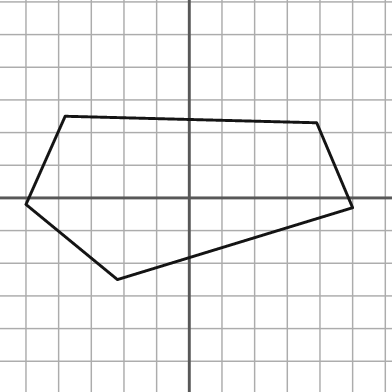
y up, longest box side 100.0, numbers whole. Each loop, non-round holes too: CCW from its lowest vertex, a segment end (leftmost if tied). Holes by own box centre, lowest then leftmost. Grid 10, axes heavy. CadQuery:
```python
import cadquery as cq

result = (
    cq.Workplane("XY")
    .moveTo(-22.0, -25.0)
    .lineTo(50.0, -3.0)
    .lineTo(39.0, 23.0)
    .lineTo(-38.0, 25.0)
    .lineTo(-50.0, -2.0)
    .close()
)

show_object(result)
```